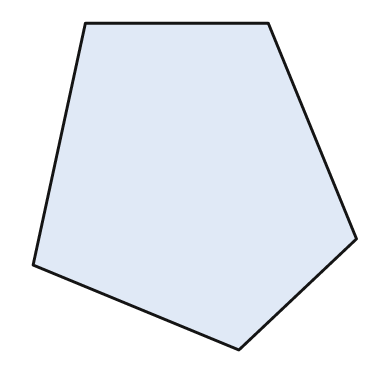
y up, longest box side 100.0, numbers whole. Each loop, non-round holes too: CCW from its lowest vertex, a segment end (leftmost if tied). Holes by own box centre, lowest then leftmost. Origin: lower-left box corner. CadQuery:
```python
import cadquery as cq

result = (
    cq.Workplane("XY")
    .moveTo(63.0, 0.0)
    .lineTo(99.0, 34.0)
    .lineTo(72.0, 100.0)
    .lineTo(16.0, 100.0)
    .lineTo(0.0, 26.0)
    .close()
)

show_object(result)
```